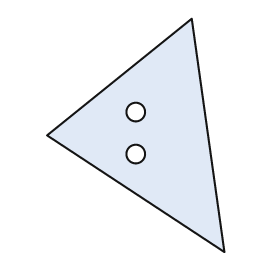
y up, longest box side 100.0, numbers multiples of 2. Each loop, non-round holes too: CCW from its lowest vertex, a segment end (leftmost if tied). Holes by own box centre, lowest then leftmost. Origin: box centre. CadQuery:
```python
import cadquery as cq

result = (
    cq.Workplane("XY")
    .moveTo(38.0, -50.0)
    .lineTo(24.0, 50.0)
    .lineTo(-38.0, 0.0)
    .close()
    .moveTo(0.0, -8.0)
    .circle(4.0)
    .moveTo(0.0, 10.0)
    .circle(4.0)
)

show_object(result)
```